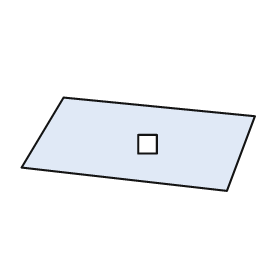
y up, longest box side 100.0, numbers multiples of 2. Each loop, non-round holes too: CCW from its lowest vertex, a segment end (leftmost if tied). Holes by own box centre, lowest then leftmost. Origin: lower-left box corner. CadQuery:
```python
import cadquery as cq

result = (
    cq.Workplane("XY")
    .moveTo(88.0, 0.0)
    .lineTo(100.0, 32.0)
    .lineTo(18.0, 40.0)
    .lineTo(0.0, 10.0)
    .close()
    .moveTo(50.0, 16.0)
    .lineTo(58.0, 16.0)
    .lineTo(58.0, 24.0)
    .lineTo(50.0, 24.0)
    .close()
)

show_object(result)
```